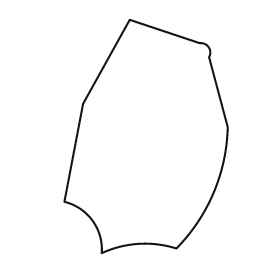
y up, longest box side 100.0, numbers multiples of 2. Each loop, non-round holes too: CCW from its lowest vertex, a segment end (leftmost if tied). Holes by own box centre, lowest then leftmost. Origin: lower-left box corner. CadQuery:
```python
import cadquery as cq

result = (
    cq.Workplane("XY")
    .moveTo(16.0, 0.0)
    .threePointArc((32.0, 4.0), (48.0, 2.0))
    .threePointArc((64.0, 26.0), (70.0, 54.0))
    .lineTo(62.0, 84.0)
    .threePointArc((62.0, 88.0), (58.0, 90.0))
    .lineTo(28.0, 100.0)
    .lineTo(8.0, 64.0)
    .lineTo(0.0, 22.0)
    .threePointArc((12.0, 14.0), (16.0, 0.0))
    .close()
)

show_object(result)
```